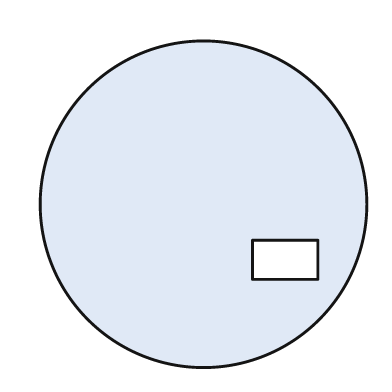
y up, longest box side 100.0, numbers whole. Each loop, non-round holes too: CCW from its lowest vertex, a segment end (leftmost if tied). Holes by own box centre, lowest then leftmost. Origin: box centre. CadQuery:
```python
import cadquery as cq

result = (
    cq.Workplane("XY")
    .moveTo(0.0, 0.0)
    .circle(50.0)
    .moveTo(15.0, -23.0)
    .lineTo(35.0, -23.0)
    .lineTo(35.0, -11.0)
    .lineTo(15.0, -11.0)
    .close()
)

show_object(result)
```